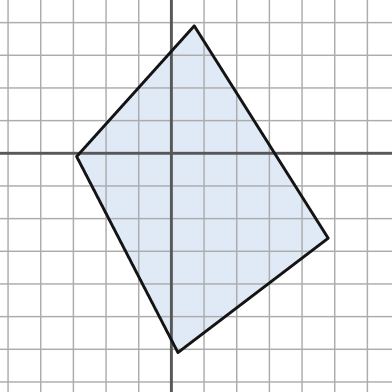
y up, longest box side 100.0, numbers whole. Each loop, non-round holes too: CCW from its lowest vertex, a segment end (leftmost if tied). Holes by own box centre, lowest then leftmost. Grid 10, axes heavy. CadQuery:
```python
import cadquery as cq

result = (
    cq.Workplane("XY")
    .moveTo(2.0, -61.0)
    .lineTo(48.0, -26.0)
    .lineTo(7.0, 39.0)
    .lineTo(-29.0, -1.0)
    .close()
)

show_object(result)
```